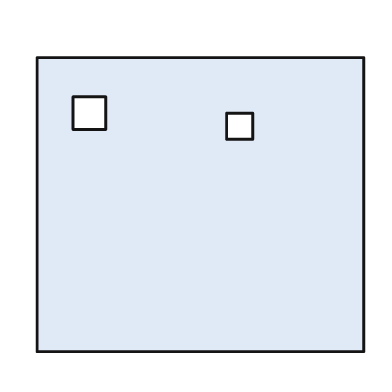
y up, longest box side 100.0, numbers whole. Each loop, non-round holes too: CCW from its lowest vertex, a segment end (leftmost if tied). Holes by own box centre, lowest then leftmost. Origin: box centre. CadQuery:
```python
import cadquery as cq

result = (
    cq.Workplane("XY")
    .moveTo(-50.0, -45.0)
    .lineTo(50.0, -45.0)
    .lineTo(50.0, 45.0)
    .lineTo(-50.0, 45.0)
    .close()
    .moveTo(8.0, 20.0)
    .lineTo(16.0, 20.0)
    .lineTo(16.0, 28.0)
    .lineTo(8.0, 28.0)
    .close()
    .moveTo(-39.0, 23.0)
    .lineTo(-29.0, 23.0)
    .lineTo(-29.0, 33.0)
    .lineTo(-39.0, 33.0)
    .close()
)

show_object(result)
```